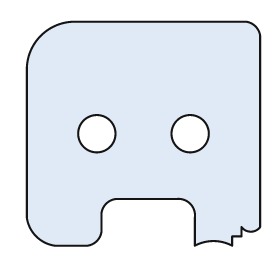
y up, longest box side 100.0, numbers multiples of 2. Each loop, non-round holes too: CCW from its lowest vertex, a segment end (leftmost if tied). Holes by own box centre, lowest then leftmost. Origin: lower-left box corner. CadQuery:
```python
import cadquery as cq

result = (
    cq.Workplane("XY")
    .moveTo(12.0, 0.0)
    .lineTo(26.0, 0.0)
    .threePointArc((30.0, 2.0), (32.0, 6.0))
    .lineTo(32.0, 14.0)
    .threePointArc((34.0, 18.0), (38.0, 20.0))
    .lineTo(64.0, 20.0)
    .threePointArc((70.0, 18.0), (72.0, 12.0))
    .lineTo(72.0, 0.0)
    .threePointArc((80.0, 2.0), (88.0, 0.0))
    .lineTo(88.0, 4.0)
    .lineTo(92.0, 4.0)
    .lineTo(92.0, 8.0)
    .threePointArc((96.0, 6.0), (100.0, 8.0))
    .lineTo(100.0, 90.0)
    .threePointArc((98.0, 94.0), (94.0, 96.0))
    .lineTo(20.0, 96.0)
    .threePointArc((6.0, 90.0), (0.0, 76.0))
    .lineTo(0.0, 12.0)
    .threePointArc((4.0, 4.0), (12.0, 0.0))
    .close()
    .moveTo(30.0, 48.0)
    .circle(8.0)
    .moveTo(70.0, 48.0)
    .circle(8.0)
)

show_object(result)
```